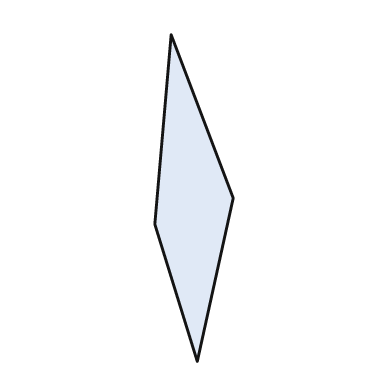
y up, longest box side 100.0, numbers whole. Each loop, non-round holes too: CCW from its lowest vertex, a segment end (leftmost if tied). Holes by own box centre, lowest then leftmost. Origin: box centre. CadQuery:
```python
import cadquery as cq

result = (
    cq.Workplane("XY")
    .moveTo(1.0, -50.0)
    .lineTo(12.0, 0.0)
    .lineTo(-7.0, 50.0)
    .lineTo(-12.0, -8.0)
    .close()
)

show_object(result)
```